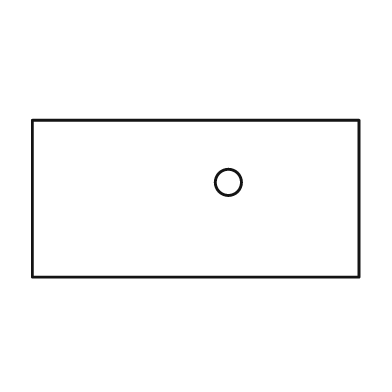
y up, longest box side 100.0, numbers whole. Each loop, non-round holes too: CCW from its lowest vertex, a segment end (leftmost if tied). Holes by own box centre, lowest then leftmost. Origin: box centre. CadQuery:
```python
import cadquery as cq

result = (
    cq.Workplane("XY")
    .moveTo(-50.0, -24.0)
    .lineTo(50.0, -24.0)
    .lineTo(50.0, 24.0)
    .lineTo(-50.0, 24.0)
    .close()
    .moveTo(10.0, 5.0)
    .circle(4.0)
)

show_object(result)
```